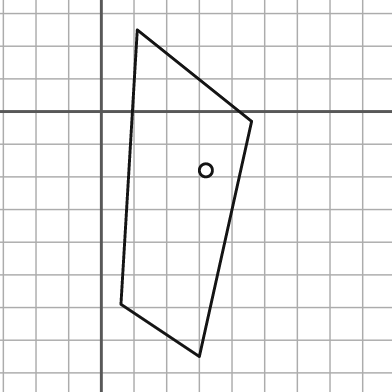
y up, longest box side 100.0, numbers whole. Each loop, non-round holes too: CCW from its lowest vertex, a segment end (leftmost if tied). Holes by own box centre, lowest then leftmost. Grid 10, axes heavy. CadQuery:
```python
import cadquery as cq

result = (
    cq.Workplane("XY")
    .moveTo(30.0, -75.0)
    .lineTo(46.0, -3.0)
    .lineTo(11.0, 25.0)
    .lineTo(6.0, -59.0)
    .close()
    .moveTo(32.0, -18.0)
    .circle(2.0)
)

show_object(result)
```